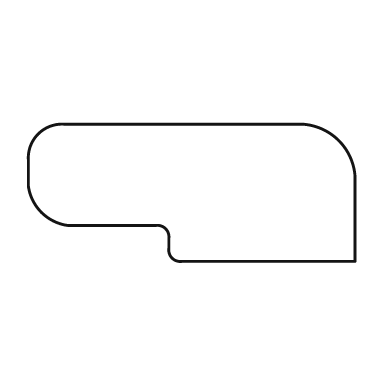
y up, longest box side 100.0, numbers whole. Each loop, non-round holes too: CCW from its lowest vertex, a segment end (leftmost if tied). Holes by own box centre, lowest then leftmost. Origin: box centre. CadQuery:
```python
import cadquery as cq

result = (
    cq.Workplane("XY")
    .moveTo(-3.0, -21.0)
    .lineTo(50.0, -21.0)
    .lineTo(50.0, 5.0)
    .threePointArc((45.0, 16.0), (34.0, 21.0))
    .lineTo(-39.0, 21.0)
    .threePointArc((-47.0, 18.0), (-50.0, 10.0))
    .lineTo(-50.0, 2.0)
    .threePointArc((-46.0, -6.0), (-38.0, -10.0))
    .lineTo(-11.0, -10.0)
    .threePointArc((-8.0, -11.0), (-7.0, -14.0))
    .lineTo(-7.0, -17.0)
    .threePointArc((-6.0, -20.0), (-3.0, -21.0))
    .close()
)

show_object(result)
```